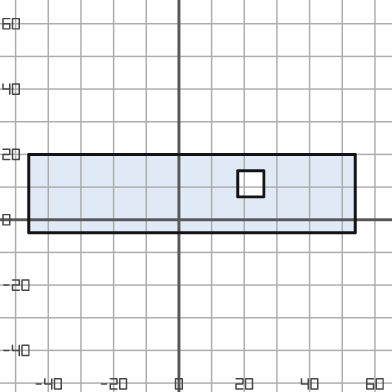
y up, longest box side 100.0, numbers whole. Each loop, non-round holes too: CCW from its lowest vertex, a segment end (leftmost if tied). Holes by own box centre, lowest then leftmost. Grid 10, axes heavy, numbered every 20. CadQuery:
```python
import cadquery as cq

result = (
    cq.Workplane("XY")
    .moveTo(-46.0, -4.0)
    .lineTo(54.0, -4.0)
    .lineTo(54.0, 20.0)
    .lineTo(-46.0, 20.0)
    .close()
    .moveTo(18.0, 7.0)
    .lineTo(26.0, 7.0)
    .lineTo(26.0, 15.0)
    .lineTo(18.0, 15.0)
    .close()
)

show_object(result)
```